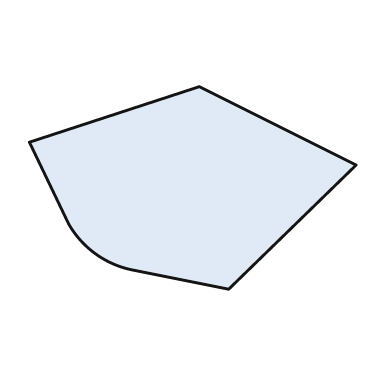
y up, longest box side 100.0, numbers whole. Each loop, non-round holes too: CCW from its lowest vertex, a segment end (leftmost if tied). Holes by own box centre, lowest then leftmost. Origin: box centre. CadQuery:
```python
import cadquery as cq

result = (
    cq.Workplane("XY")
    .moveTo(11.0, -31.0)
    .lineTo(50.0, 7.0)
    .lineTo(2.0, 31.0)
    .lineTo(-50.0, 14.0)
    .lineTo(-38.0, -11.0)
    .threePointArc((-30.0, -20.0), (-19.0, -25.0))
    .close()
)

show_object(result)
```